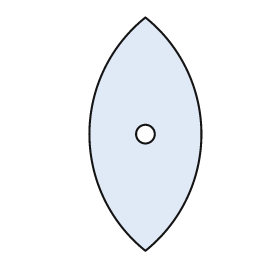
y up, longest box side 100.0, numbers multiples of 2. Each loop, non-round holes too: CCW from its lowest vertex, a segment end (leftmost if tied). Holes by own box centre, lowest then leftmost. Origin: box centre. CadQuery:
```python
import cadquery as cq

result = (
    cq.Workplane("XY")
    .moveTo(0.0, -50.0)
    .threePointArc((24.0, 0.0), (0.0, 50.0))
    .threePointArc((-24.0, 0.0), (0.0, -50.0))
    .close()
    .moveTo(0.0, 0.0)
    .circle(4.0)
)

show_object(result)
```